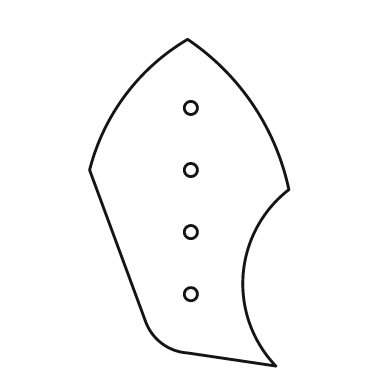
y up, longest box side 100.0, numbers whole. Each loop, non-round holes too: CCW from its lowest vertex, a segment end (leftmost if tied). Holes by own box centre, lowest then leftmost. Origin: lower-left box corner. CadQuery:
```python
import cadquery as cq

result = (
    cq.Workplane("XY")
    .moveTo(57.0, 0.0)
    .threePointArc((47.0, 28.0), (61.0, 54.0))
    .threePointArc((50.0, 80.0), (30.0, 100.0))
    .threePointArc((11.0, 83.0), (0.0, 60.0))
    .lineTo(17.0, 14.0)
    .threePointArc((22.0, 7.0), (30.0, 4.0))
    .close()
    .moveTo(31.0, 22.0)
    .circle(2.0)
    .moveTo(31.0, 41.0)
    .circle(2.0)
    .moveTo(31.0, 60.0)
    .circle(2.0)
    .moveTo(31.0, 79.0)
    .circle(2.0)
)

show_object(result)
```